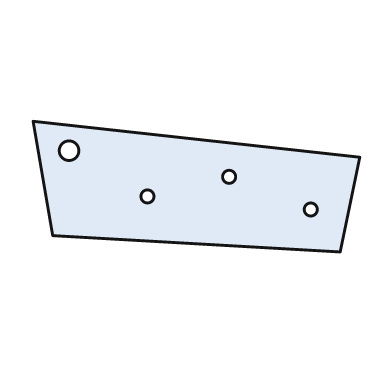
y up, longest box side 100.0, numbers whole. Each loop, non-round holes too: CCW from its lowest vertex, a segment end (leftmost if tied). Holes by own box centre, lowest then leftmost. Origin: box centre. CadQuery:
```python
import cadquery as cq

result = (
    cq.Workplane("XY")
    .moveTo(44.0, -20.0)
    .lineTo(50.0, 9.0)
    .lineTo(-50.0, 20.0)
    .lineTo(-44.0, -15.0)
    .close()
    .moveTo(35.0, -7.0)
    .circle(2.0)
    .moveTo(-15.0, -3.0)
    .circle(2.0)
    .moveTo(10.0, 3.0)
    .circle(2.0)
    .moveTo(-39.0, 11.0)
    .circle(3.0)
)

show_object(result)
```